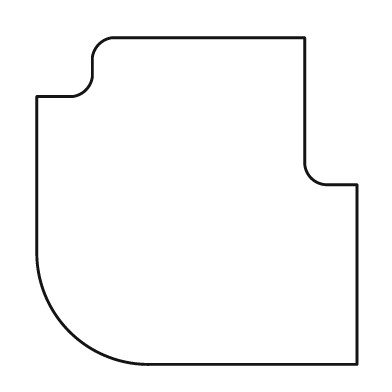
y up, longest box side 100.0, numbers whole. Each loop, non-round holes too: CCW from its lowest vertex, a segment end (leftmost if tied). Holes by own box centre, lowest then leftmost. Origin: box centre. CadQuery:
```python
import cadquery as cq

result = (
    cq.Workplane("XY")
    .moveTo(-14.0, -50.0)
    .lineTo(49.0, -50.0)
    .lineTo(49.0, 5.0)
    .lineTo(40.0, 5.0)
    .threePointArc((35.0, 7.0), (33.0, 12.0))
    .lineTo(33.0, 50.0)
    .lineTo(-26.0, 50.0)
    .threePointArc((-30.0, 48.0), (-32.0, 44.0))
    .lineTo(-32.0, 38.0)
    .threePointArc((-34.0, 34.0), (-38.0, 32.0))
    .lineTo(-49.0, 32.0)
    .lineTo(-49.0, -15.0)
    .threePointArc((-39.0, -40.0), (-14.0, -50.0))
    .close()
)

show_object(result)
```